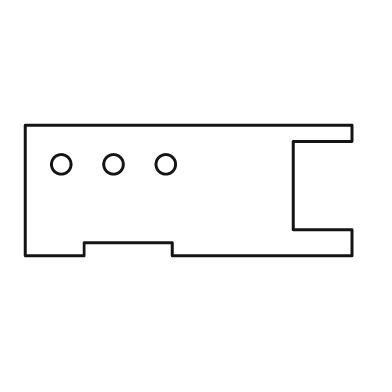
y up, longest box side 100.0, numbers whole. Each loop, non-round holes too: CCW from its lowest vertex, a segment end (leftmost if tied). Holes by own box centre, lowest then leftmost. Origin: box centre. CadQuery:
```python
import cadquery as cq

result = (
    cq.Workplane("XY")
    .moveTo(-50.0, -20.0)
    .lineTo(-32.0, -20.0)
    .lineTo(-32.0, -16.0)
    .lineTo(-5.0, -16.0)
    .lineTo(-5.0, -20.0)
    .lineTo(50.0, -20.0)
    .lineTo(50.0, -12.0)
    .lineTo(32.0, -12.0)
    .lineTo(32.0, 15.0)
    .lineTo(50.0, 15.0)
    .lineTo(50.0, 20.0)
    .lineTo(-50.0, 20.0)
    .close()
    .moveTo(-39.0, 8.0)
    .circle(3.0)
    .moveTo(-23.0, 8.0)
    .circle(3.0)
    .moveTo(-7.0, 8.0)
    .circle(3.0)
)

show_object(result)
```